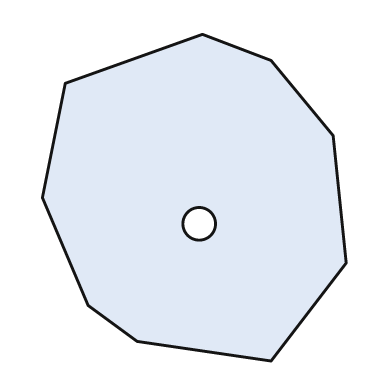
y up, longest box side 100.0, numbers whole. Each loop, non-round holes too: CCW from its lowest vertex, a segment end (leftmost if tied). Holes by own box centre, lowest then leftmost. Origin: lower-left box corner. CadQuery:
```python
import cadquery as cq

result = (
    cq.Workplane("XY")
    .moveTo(70.0, 0.0)
    .lineTo(93.0, 30.0)
    .lineTo(89.0, 69.0)
    .lineTo(70.0, 92.0)
    .lineTo(49.0, 100.0)
    .lineTo(7.0, 85.0)
    .lineTo(0.0, 50.0)
    .lineTo(14.0, 17.0)
    .lineTo(29.0, 6.0)
    .close()
    .moveTo(48.0, 42.0)
    .circle(5.0)
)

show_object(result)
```